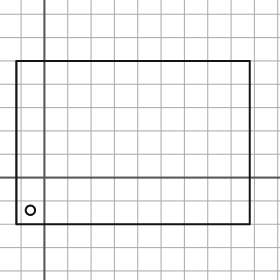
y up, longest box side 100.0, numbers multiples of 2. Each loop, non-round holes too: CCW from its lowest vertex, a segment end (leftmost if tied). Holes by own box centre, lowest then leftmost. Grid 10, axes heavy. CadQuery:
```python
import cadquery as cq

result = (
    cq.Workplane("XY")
    .moveTo(-12.0, -20.0)
    .lineTo(88.0, -20.0)
    .lineTo(88.0, 50.0)
    .lineTo(-12.0, 50.0)
    .close()
    .moveTo(-6.0, -14.0)
    .circle(2.0)
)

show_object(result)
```